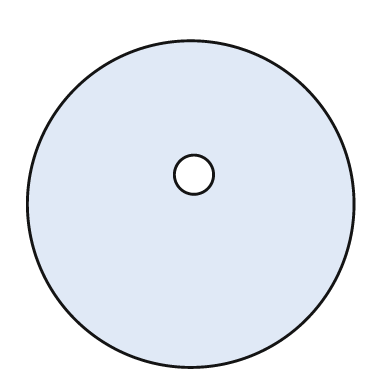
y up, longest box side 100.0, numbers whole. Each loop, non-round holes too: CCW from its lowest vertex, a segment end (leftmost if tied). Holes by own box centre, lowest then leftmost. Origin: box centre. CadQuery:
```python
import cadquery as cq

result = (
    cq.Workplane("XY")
    .moveTo(0.0, 0.0)
    .circle(50.0)
    .moveTo(1.0, 9.0)
    .circle(6.0)
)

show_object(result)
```